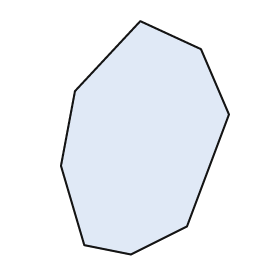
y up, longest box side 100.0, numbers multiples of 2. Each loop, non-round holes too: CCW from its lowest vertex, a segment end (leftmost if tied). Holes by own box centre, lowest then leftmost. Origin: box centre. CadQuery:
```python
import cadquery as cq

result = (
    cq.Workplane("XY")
    .moveTo(-6.0, -50.0)
    .lineTo(18.0, -38.0)
    .lineTo(36.0, 10.0)
    .lineTo(24.0, 38.0)
    .lineTo(-2.0, 50.0)
    .lineTo(-30.0, 20.0)
    .lineTo(-36.0, -12.0)
    .lineTo(-26.0, -46.0)
    .close()
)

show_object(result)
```